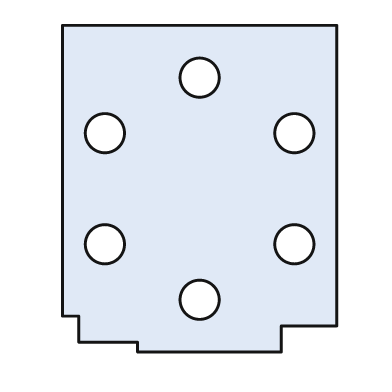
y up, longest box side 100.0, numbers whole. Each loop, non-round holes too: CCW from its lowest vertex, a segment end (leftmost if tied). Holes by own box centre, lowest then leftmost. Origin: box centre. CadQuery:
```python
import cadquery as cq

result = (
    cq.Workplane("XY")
    .moveTo(-19.0, -50.0)
    .lineTo(25.0, -50.0)
    .lineTo(25.0, -42.0)
    .lineTo(42.0, -42.0)
    .lineTo(42.0, 50.0)
    .lineTo(-42.0, 50.0)
    .lineTo(-42.0, -39.0)
    .lineTo(-37.0, -39.0)
    .lineTo(-37.0, -47.0)
    .lineTo(-19.0, -47.0)
    .close()
    .moveTo(0.0, -34.0)
    .circle(6.0)
    .moveTo(-29.0, -17.0)
    .circle(6.0)
    .moveTo(29.0, -17.0)
    .circle(6.0)
    .moveTo(-29.0, 17.0)
    .circle(6.0)
    .moveTo(29.0, 17.0)
    .circle(6.0)
    .moveTo(0.0, 34.0)
    .circle(6.0)
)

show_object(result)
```